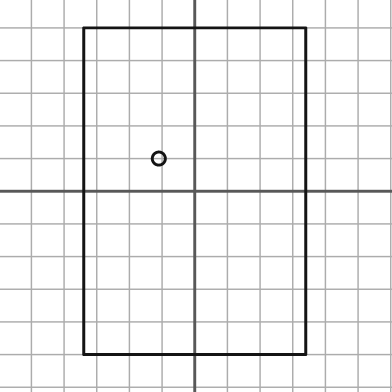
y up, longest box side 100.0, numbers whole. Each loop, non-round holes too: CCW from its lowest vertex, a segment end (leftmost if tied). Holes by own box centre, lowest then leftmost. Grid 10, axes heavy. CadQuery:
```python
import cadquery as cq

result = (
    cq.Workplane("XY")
    .moveTo(-34.0, -50.0)
    .lineTo(34.0, -50.0)
    .lineTo(34.0, 50.0)
    .lineTo(-34.0, 50.0)
    .close()
    .moveTo(-11.0, 10.0)
    .circle(2.0)
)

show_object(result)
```